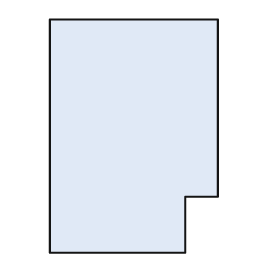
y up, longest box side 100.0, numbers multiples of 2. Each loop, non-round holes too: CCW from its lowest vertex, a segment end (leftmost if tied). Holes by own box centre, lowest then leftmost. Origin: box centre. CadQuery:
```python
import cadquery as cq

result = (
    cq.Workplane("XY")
    .moveTo(-36.0, -50.0)
    .lineTo(22.0, -50.0)
    .lineTo(22.0, -26.0)
    .lineTo(36.0, -26.0)
    .lineTo(36.0, 50.0)
    .lineTo(-36.0, 50.0)
    .close()
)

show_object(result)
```